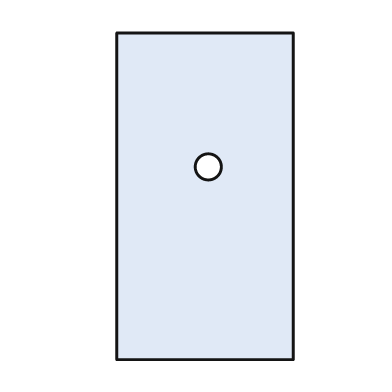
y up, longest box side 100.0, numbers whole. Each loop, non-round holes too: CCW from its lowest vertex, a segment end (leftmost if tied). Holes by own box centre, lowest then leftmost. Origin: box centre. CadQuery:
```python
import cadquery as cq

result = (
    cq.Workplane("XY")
    .moveTo(-27.0, -50.0)
    .lineTo(27.0, -50.0)
    .lineTo(27.0, 50.0)
    .lineTo(-27.0, 50.0)
    .close()
    .moveTo(1.0, 9.0)
    .circle(4.0)
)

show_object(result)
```